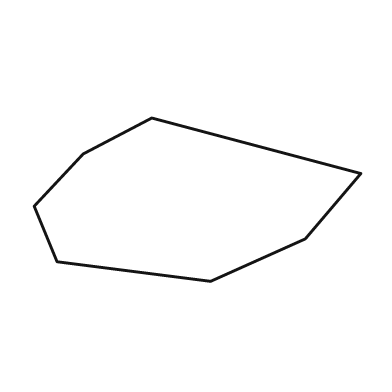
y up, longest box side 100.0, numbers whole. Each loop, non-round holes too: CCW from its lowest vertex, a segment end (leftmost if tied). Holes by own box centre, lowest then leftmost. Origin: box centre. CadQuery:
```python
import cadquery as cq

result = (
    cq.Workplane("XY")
    .moveTo(4.0, -25.0)
    .lineTo(33.0, -12.0)
    .lineTo(50.0, 8.0)
    .lineTo(-14.0, 25.0)
    .lineTo(-35.0, 14.0)
    .lineTo(-50.0, -2.0)
    .lineTo(-43.0, -19.0)
    .close()
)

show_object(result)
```